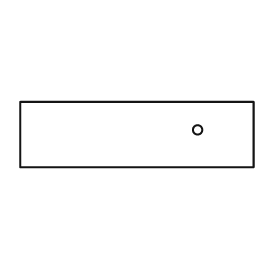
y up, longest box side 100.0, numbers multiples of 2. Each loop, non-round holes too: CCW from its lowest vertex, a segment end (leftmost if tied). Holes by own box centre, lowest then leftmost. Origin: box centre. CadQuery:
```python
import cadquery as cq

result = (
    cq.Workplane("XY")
    .moveTo(-50.0, -14.0)
    .lineTo(50.0, -14.0)
    .lineTo(50.0, 14.0)
    .lineTo(-50.0, 14.0)
    .close()
    .moveTo(26.0, 2.0)
    .circle(2.0)
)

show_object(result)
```